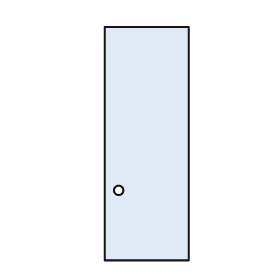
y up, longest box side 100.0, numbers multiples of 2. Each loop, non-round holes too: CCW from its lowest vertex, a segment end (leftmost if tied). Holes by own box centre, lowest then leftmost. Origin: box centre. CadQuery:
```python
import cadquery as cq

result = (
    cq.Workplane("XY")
    .moveTo(-18.0, -50.0)
    .lineTo(18.0, -50.0)
    .lineTo(18.0, 50.0)
    .lineTo(-18.0, 50.0)
    .close()
    .moveTo(-12.0, -20.0)
    .circle(2.0)
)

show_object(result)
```